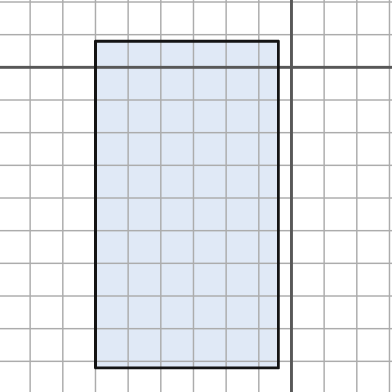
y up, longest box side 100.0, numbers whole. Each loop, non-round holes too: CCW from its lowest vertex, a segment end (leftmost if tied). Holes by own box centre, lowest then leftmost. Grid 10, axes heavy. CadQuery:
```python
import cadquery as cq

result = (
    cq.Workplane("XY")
    .moveTo(-60.0, -92.0)
    .lineTo(-4.0, -92.0)
    .lineTo(-4.0, 8.0)
    .lineTo(-60.0, 8.0)
    .close()
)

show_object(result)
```